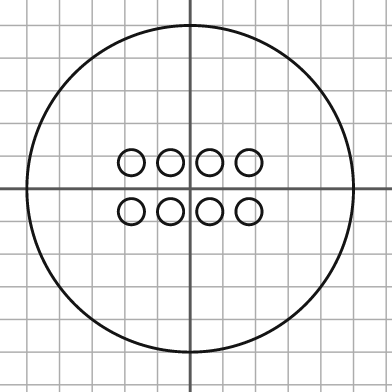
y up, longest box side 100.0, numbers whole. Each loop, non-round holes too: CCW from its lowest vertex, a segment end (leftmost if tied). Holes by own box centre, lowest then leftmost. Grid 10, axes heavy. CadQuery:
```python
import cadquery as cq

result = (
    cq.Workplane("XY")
    .moveTo(0.0, 0.0)
    .circle(50.0)
    .moveTo(-18.0, -7.0)
    .circle(4.0)
    .moveTo(-6.0, -7.0)
    .circle(4.0)
    .moveTo(6.0, -7.0)
    .circle(4.0)
    .moveTo(18.0, -7.0)
    .circle(4.0)
    .moveTo(-18.0, 8.0)
    .circle(4.0)
    .moveTo(-6.0, 8.0)
    .circle(4.0)
    .moveTo(6.0, 8.0)
    .circle(4.0)
    .moveTo(18.0, 8.0)
    .circle(4.0)
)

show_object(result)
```